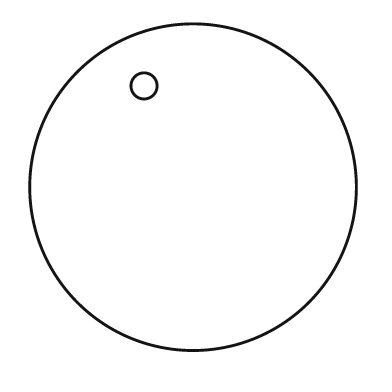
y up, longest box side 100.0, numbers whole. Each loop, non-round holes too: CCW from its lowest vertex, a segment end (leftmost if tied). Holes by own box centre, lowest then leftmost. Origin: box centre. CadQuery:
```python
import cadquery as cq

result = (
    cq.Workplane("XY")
    .moveTo(0.0, 0.0)
    .circle(50.0)
    .moveTo(-15.0, 31.0)
    .circle(4.0)
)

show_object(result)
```